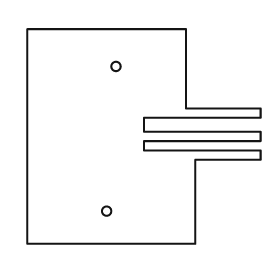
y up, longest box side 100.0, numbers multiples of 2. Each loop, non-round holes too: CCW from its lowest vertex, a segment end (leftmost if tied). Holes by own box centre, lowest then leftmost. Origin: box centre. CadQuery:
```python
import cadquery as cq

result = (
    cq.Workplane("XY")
    .moveTo(-50.0, -46.0)
    .lineTo(22.0, -46.0)
    .lineTo(22.0, -10.0)
    .lineTo(50.0, -10.0)
    .lineTo(50.0, -6.0)
    .lineTo(0.0, -6.0)
    .lineTo(0.0, -2.0)
    .lineTo(50.0, -2.0)
    .lineTo(50.0, 2.0)
    .lineTo(0.0, 2.0)
    .lineTo(0.0, 8.0)
    .lineTo(50.0, 8.0)
    .lineTo(50.0, 12.0)
    .lineTo(18.0, 12.0)
    .lineTo(18.0, 46.0)
    .lineTo(-50.0, 46.0)
    .close()
    .moveTo(-16.0, -32.0)
    .circle(2.0)
    .moveTo(-12.0, 30.0)
    .circle(2.0)
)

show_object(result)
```